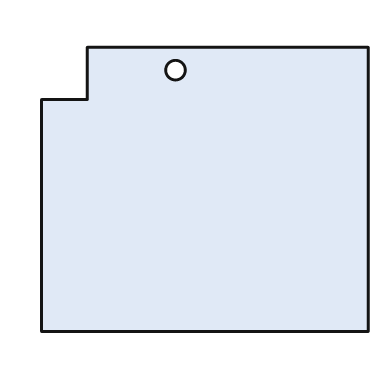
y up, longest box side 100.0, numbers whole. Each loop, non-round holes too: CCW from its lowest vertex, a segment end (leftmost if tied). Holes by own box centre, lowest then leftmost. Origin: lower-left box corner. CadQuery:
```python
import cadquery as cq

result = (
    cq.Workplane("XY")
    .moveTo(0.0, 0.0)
    .lineTo(100.0, 0.0)
    .lineTo(100.0, 87.0)
    .lineTo(14.0, 87.0)
    .lineTo(14.0, 71.0)
    .lineTo(0.0, 71.0)
    .close()
    .moveTo(41.0, 80.0)
    .circle(3.0)
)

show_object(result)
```